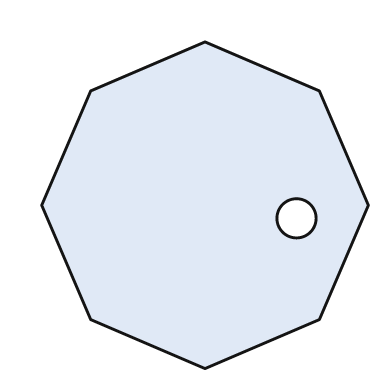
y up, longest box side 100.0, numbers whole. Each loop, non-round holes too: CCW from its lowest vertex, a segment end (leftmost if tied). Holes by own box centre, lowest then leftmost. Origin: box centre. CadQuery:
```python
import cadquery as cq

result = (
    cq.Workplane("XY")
    .moveTo(0.0, -50.0)
    .lineTo(35.0, -35.0)
    .lineTo(50.0, 0.0)
    .lineTo(35.0, 35.0)
    .lineTo(0.0, 50.0)
    .lineTo(-35.0, 35.0)
    .lineTo(-50.0, 0.0)
    .lineTo(-35.0, -35.0)
    .close()
    .moveTo(28.0, -4.0)
    .circle(6.0)
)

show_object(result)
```